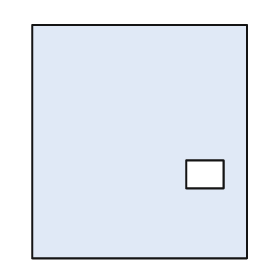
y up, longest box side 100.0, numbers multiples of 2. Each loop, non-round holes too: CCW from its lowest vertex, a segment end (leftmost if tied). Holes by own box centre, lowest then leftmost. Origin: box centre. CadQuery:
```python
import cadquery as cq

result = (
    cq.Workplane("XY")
    .moveTo(-46.0, -50.0)
    .lineTo(46.0, -50.0)
    .lineTo(46.0, 50.0)
    .lineTo(-46.0, 50.0)
    .close()
    .moveTo(20.0, -20.0)
    .lineTo(36.0, -20.0)
    .lineTo(36.0, -8.0)
    .lineTo(20.0, -8.0)
    .close()
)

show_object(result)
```